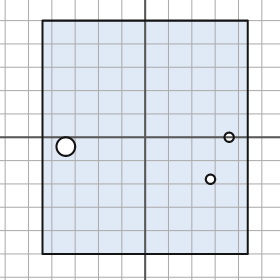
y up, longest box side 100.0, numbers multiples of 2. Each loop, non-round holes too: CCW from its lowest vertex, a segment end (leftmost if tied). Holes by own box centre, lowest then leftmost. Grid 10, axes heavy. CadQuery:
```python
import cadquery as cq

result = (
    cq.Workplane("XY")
    .moveTo(-44.0, -50.0)
    .lineTo(44.0, -50.0)
    .lineTo(44.0, 50.0)
    .lineTo(-44.0, 50.0)
    .close()
    .moveTo(28.0, -18.0)
    .circle(2.0)
    .moveTo(-34.0, -4.0)
    .circle(4.0)
    .moveTo(36.0, 0.0)
    .circle(2.0)
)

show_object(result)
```